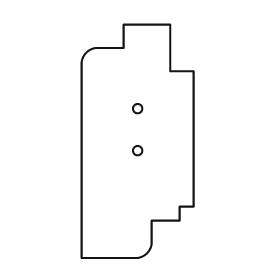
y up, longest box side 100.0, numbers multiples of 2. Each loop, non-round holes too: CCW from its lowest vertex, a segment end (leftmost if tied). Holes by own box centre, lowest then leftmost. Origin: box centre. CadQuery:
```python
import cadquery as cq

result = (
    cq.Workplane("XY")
    .moveTo(-24.0, -50.0)
    .lineTo(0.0, -50.0)
    .threePointArc((4.0, -48.0), (6.0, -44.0))
    .lineTo(6.0, -34.0)
    .lineTo(18.0, -34.0)
    .lineTo(18.0, -28.0)
    .lineTo(24.0, -28.0)
    .lineTo(24.0, 30.0)
    .lineTo(14.0, 30.0)
    .lineTo(14.0, 50.0)
    .lineTo(-6.0, 50.0)
    .lineTo(-6.0, 40.0)
    .lineTo(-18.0, 40.0)
    .threePointArc((-22.0, 38.0), (-24.0, 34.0))
    .close()
    .moveTo(0.0, -4.0)
    .circle(2.0)
    .moveTo(0.0, 14.0)
    .circle(2.0)
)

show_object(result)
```